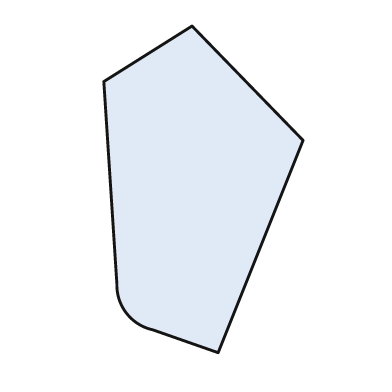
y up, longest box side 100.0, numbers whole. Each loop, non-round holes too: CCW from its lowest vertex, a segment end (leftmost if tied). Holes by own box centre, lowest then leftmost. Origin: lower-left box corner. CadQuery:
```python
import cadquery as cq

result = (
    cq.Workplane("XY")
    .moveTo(35.0, 0.0)
    .lineTo(61.0, 65.0)
    .lineTo(27.0, 100.0)
    .lineTo(0.0, 83.0)
    .lineTo(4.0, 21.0)
    .threePointArc((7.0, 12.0), (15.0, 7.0))
    .close()
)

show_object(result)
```